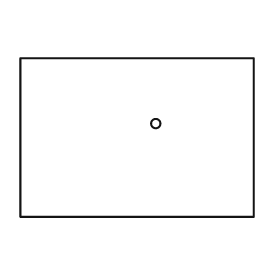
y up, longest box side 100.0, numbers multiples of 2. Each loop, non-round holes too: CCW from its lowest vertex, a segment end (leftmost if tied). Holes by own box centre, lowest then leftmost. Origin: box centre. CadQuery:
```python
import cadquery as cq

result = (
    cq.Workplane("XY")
    .moveTo(-50.0, -34.0)
    .lineTo(50.0, -34.0)
    .lineTo(50.0, 34.0)
    .lineTo(-50.0, 34.0)
    .close()
    .moveTo(8.0, 6.0)
    .circle(2.0)
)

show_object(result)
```